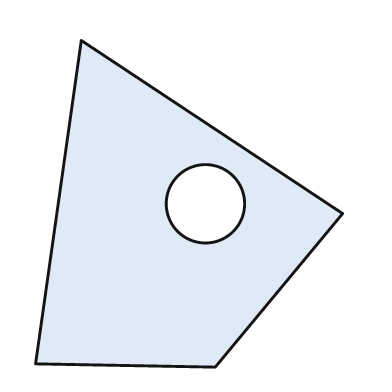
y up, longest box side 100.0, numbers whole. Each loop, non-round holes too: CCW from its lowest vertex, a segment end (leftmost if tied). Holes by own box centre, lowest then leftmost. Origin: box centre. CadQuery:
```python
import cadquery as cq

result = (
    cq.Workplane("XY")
    .moveTo(8.0, -50.0)
    .lineTo(47.0, -3.0)
    .lineTo(-33.0, 50.0)
    .lineTo(-47.0, -49.0)
    .close()
    .moveTo(5.0, 0.0)
    .circle(12.0)
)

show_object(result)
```